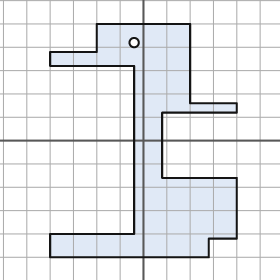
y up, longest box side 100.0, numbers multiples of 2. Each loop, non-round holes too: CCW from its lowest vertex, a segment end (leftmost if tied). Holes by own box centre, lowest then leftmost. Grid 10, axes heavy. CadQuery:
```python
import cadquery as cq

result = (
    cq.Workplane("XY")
    .moveTo(-40.0, -50.0)
    .lineTo(28.0, -50.0)
    .lineTo(28.0, -42.0)
    .lineTo(40.0, -42.0)
    .lineTo(40.0, -16.0)
    .lineTo(8.0, -16.0)
    .lineTo(8.0, 12.0)
    .lineTo(40.0, 12.0)
    .lineTo(40.0, 16.0)
    .lineTo(20.0, 16.0)
    .lineTo(20.0, 50.0)
    .lineTo(-20.0, 50.0)
    .lineTo(-20.0, 38.0)
    .lineTo(-40.0, 38.0)
    .lineTo(-40.0, 32.0)
    .lineTo(-4.0, 32.0)
    .lineTo(-4.0, -40.0)
    .lineTo(-40.0, -40.0)
    .close()
    .moveTo(-4.0, 42.0)
    .circle(2.0)
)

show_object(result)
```